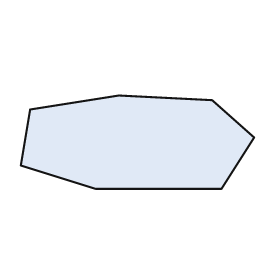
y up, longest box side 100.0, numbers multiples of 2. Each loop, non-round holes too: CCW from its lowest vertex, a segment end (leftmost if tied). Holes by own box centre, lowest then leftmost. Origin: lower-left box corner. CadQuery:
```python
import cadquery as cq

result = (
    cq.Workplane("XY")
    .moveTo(32.0, 0.0)
    .lineTo(86.0, 0.0)
    .lineTo(100.0, 22.0)
    .lineTo(82.0, 38.0)
    .lineTo(42.0, 40.0)
    .lineTo(4.0, 34.0)
    .lineTo(0.0, 10.0)
    .close()
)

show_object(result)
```